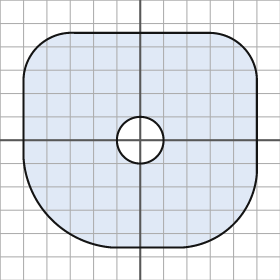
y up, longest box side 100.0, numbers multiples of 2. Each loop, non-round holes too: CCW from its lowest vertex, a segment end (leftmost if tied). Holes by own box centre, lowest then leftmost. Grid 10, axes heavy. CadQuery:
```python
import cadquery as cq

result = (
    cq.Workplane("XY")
    .moveTo(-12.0, -46.0)
    .lineTo(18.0, -46.0)
    .threePointArc((40.0, -36.0), (50.0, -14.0))
    .lineTo(50.0, 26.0)
    .threePointArc((44.0, 40.0), (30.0, 46.0))
    .lineTo(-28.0, 46.0)
    .threePointArc((-44.0, 40.0), (-50.0, 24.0))
    .lineTo(-50.0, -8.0)
    .threePointArc((-38.0, -34.0), (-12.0, -46.0))
    .close()
    .moveTo(0.0, 0.0)
    .circle(10.0)
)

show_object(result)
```